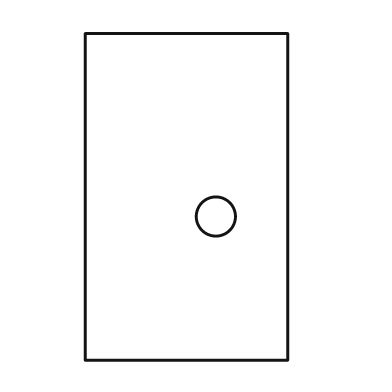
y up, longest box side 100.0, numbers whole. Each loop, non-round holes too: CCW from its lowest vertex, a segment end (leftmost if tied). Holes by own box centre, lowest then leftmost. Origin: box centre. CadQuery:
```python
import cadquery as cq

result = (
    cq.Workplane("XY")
    .moveTo(-31.0, -50.0)
    .lineTo(31.0, -50.0)
    .lineTo(31.0, 50.0)
    .lineTo(-31.0, 50.0)
    .close()
    .moveTo(9.0, -6.0)
    .circle(6.0)
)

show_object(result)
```